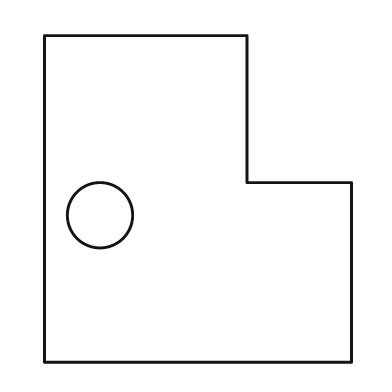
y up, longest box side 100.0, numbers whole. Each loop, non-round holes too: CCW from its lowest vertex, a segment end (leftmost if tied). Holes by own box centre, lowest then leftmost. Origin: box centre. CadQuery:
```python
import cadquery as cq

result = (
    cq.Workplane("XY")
    .moveTo(-47.0, -50.0)
    .lineTo(47.0, -50.0)
    .lineTo(47.0, 5.0)
    .lineTo(15.0, 5.0)
    .lineTo(15.0, 50.0)
    .lineTo(-47.0, 50.0)
    .close()
    .moveTo(-30.0, -5.0)
    .circle(10.0)
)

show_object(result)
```